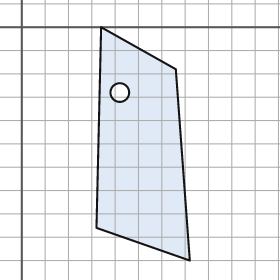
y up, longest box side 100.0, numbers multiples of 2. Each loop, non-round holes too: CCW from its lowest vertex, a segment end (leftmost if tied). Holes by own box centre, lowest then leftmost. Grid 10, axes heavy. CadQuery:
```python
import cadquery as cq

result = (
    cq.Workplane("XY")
    .moveTo(72.0, -100.0)
    .lineTo(66.0, -18.0)
    .lineTo(34.0, 0.0)
    .lineTo(32.0, -86.0)
    .close()
    .moveTo(42.0, -28.0)
    .circle(4.0)
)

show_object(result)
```